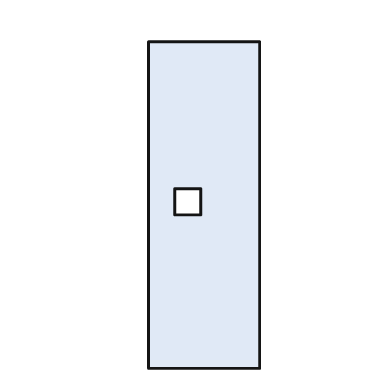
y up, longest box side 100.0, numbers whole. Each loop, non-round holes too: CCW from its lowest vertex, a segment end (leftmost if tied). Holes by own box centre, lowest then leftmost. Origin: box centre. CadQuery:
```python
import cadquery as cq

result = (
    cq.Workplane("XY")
    .moveTo(-17.0, -50.0)
    .lineTo(17.0, -50.0)
    .lineTo(17.0, 50.0)
    .lineTo(-17.0, 50.0)
    .close()
    .moveTo(-9.0, -3.0)
    .lineTo(-1.0, -3.0)
    .lineTo(-1.0, 5.0)
    .lineTo(-9.0, 5.0)
    .close()
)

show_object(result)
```